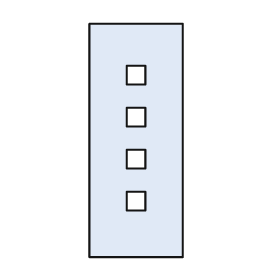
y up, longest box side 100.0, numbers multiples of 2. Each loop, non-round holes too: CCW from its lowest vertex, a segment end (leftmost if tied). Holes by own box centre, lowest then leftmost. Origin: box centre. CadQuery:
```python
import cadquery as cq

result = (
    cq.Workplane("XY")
    .moveTo(-20.0, -50.0)
    .lineTo(20.0, -50.0)
    .lineTo(20.0, 50.0)
    .lineTo(-20.0, 50.0)
    .close()
    .moveTo(-4.0, -30.0)
    .lineTo(4.0, -30.0)
    .lineTo(4.0, -22.0)
    .lineTo(-4.0, -22.0)
    .close()
    .moveTo(-4.0, -12.0)
    .lineTo(4.0, -12.0)
    .lineTo(4.0, -4.0)
    .lineTo(-4.0, -4.0)
    .close()
    .moveTo(-4.0, 6.0)
    .lineTo(4.0, 6.0)
    .lineTo(4.0, 14.0)
    .lineTo(-4.0, 14.0)
    .close()
    .moveTo(-4.0, 24.0)
    .lineTo(4.0, 24.0)
    .lineTo(4.0, 32.0)
    .lineTo(-4.0, 32.0)
    .close()
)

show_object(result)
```